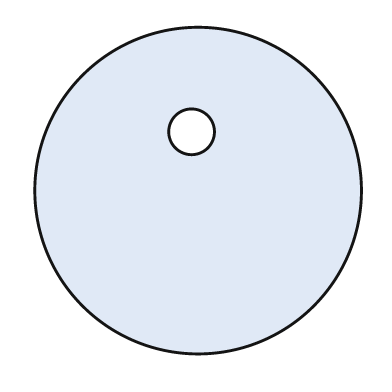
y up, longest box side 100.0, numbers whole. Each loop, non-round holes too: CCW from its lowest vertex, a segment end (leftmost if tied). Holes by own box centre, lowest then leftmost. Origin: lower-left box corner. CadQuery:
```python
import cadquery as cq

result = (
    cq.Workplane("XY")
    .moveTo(50.0, 50.0)
    .circle(50.0)
    .moveTo(48.0, 68.0)
    .circle(7.0)
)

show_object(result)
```